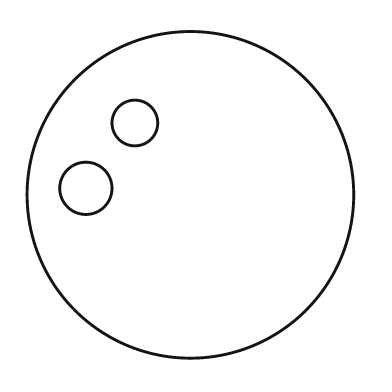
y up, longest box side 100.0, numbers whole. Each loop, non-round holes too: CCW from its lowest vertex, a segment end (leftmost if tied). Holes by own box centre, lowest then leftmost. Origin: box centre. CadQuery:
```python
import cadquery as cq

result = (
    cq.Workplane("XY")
    .moveTo(0.0, 0.0)
    .circle(50.0)
    .moveTo(-32.0, 2.0)
    .circle(8.0)
    .moveTo(-17.0, 22.0)
    .circle(7.0)
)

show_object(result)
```